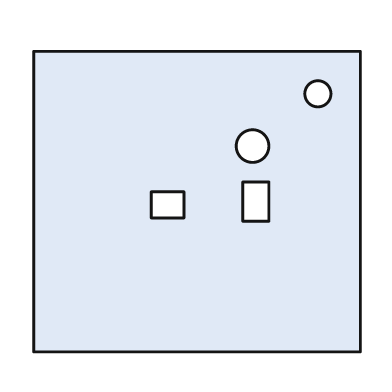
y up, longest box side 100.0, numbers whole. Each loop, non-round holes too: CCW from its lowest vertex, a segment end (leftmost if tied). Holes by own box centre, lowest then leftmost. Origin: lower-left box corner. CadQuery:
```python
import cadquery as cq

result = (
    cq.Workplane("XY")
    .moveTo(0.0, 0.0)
    .lineTo(100.0, 0.0)
    .lineTo(100.0, 92.0)
    .lineTo(0.0, 92.0)
    .close()
    .moveTo(36.0, 41.0)
    .lineTo(46.0, 41.0)
    .lineTo(46.0, 49.0)
    .lineTo(36.0, 49.0)
    .close()
    .moveTo(64.0, 40.0)
    .lineTo(72.0, 40.0)
    .lineTo(72.0, 52.0)
    .lineTo(64.0, 52.0)
    .close()
    .moveTo(67.0, 63.0)
    .circle(5.0)
    .moveTo(87.0, 79.0)
    .circle(4.0)
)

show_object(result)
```